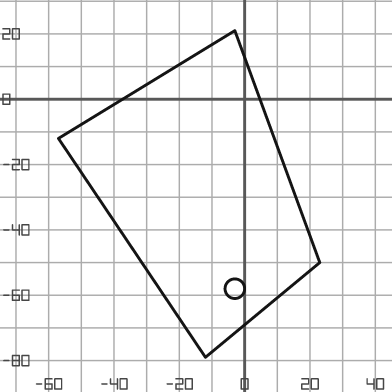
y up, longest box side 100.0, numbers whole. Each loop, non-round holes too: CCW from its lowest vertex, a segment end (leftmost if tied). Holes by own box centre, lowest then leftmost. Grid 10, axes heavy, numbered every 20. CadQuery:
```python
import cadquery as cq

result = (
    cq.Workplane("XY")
    .moveTo(-12.0, -79.0)
    .lineTo(23.0, -50.0)
    .lineTo(-3.0, 21.0)
    .lineTo(-57.0, -12.0)
    .close()
    .moveTo(-3.0, -58.0)
    .circle(3.0)
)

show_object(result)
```